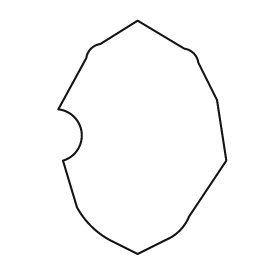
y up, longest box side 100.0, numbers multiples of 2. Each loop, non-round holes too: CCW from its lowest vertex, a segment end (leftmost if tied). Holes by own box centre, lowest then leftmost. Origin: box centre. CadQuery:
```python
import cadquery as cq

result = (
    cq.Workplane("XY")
    .moveTo(-2.0, -50.0)
    .lineTo(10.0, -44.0)
    .threePointArc((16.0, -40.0), (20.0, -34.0))
    .lineTo(36.0, -10.0)
    .lineTo(32.0, 16.0)
    .lineTo(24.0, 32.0)
    .threePointArc((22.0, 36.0), (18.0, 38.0))
    .lineTo(-2.0, 50.0)
    .lineTo(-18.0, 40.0)
    .threePointArc((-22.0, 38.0), (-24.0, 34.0))
    .lineTo(-36.0, 12.0)
    .threePointArc((-26.0, 2.0), (-34.0, -10.0))
    .lineTo(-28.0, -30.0)
    .threePointArc((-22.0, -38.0), (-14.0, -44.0))
    .close()
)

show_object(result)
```